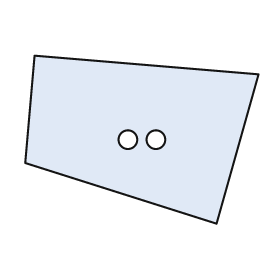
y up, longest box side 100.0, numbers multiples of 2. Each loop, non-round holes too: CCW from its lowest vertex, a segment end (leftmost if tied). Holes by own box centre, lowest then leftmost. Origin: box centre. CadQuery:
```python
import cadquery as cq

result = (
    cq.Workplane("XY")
    .moveTo(32.0, -36.0)
    .lineTo(50.0, 28.0)
    .lineTo(-46.0, 36.0)
    .lineTo(-50.0, -10.0)
    .close()
    .moveTo(-6.0, 0.0)
    .circle(4.0)
    .moveTo(6.0, 0.0)
    .circle(4.0)
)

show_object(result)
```